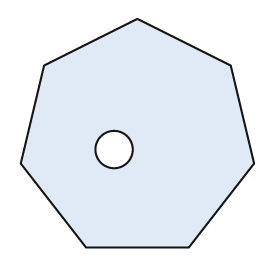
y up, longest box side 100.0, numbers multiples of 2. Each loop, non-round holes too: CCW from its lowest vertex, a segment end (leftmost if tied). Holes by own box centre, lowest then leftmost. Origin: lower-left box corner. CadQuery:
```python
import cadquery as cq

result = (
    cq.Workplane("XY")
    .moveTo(28.0, 0.0)
    .lineTo(72.0, 0.0)
    .lineTo(100.0, 36.0)
    .lineTo(90.0, 78.0)
    .lineTo(50.0, 98.0)
    .lineTo(10.0, 78.0)
    .lineTo(0.0, 36.0)
    .close()
    .moveTo(40.0, 42.0)
    .circle(8.0)
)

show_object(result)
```